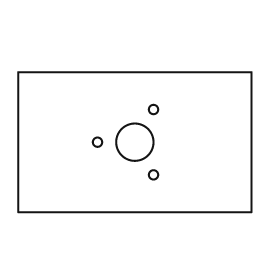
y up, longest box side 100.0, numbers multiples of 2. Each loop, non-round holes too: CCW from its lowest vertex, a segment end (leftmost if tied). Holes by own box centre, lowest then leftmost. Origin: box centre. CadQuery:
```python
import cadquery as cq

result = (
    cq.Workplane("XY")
    .moveTo(-50.0, -30.0)
    .lineTo(50.0, -30.0)
    .lineTo(50.0, 30.0)
    .lineTo(-50.0, 30.0)
    .close()
    .moveTo(8.0, -14.0)
    .circle(2.0)
    .moveTo(-16.0, 0.0)
    .circle(2.0)
    .moveTo(0.0, 0.0)
    .circle(8.0)
    .moveTo(8.0, 14.0)
    .circle(2.0)
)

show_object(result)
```